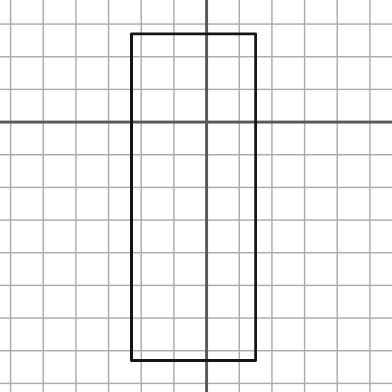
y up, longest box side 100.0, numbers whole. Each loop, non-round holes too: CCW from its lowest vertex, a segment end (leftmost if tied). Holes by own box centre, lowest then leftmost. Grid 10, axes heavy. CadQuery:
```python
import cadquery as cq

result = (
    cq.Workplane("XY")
    .moveTo(-23.0, -73.0)
    .lineTo(15.0, -73.0)
    .lineTo(15.0, 27.0)
    .lineTo(-23.0, 27.0)
    .close()
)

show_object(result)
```